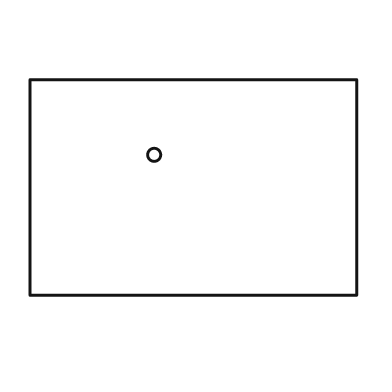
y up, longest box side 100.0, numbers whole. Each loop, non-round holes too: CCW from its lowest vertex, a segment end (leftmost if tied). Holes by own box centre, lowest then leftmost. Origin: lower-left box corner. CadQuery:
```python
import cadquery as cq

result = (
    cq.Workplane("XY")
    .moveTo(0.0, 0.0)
    .lineTo(100.0, 0.0)
    .lineTo(100.0, 66.0)
    .lineTo(0.0, 66.0)
    .close()
    .moveTo(38.0, 43.0)
    .circle(2.0)
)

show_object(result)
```